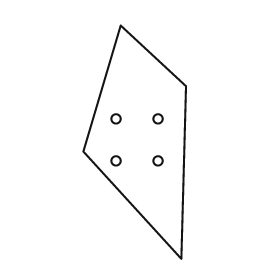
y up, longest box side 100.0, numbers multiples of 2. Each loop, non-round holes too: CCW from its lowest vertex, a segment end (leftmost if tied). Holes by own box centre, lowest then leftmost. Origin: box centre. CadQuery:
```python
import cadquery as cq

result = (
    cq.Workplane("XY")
    .moveTo(20.0, -50.0)
    .lineTo(22.0, 24.0)
    .lineTo(-6.0, 50.0)
    .lineTo(-22.0, -4.0)
    .close()
    .moveTo(-8.0, -8.0)
    .circle(2.0)
    .moveTo(10.0, -8.0)
    .circle(2.0)
    .moveTo(-8.0, 10.0)
    .circle(2.0)
    .moveTo(10.0, 10.0)
    .circle(2.0)
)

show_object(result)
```